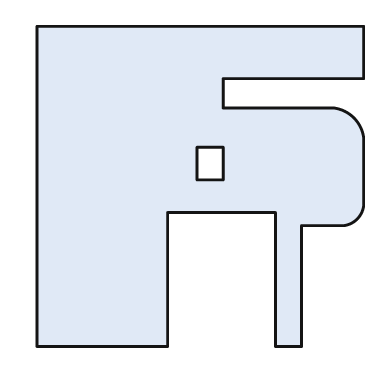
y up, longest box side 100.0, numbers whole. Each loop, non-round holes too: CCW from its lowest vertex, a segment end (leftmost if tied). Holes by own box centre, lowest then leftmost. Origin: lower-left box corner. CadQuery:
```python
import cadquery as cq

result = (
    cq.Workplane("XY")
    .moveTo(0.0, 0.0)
    .lineTo(40.0, 0.0)
    .lineTo(40.0, 41.0)
    .lineTo(73.0, 41.0)
    .lineTo(73.0, 0.0)
    .lineTo(81.0, 0.0)
    .lineTo(81.0, 37.0)
    .lineTo(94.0, 37.0)
    .threePointArc((98.0, 39.0), (100.0, 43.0))
    .lineTo(100.0, 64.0)
    .threePointArc((97.0, 70.0), (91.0, 73.0))
    .lineTo(57.0, 73.0)
    .lineTo(57.0, 82.0)
    .lineTo(100.0, 82.0)
    .lineTo(100.0, 98.0)
    .lineTo(0.0, 98.0)
    .close()
    .moveTo(49.0, 51.0)
    .lineTo(57.0, 51.0)
    .lineTo(57.0, 61.0)
    .lineTo(49.0, 61.0)
    .close()
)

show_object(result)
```